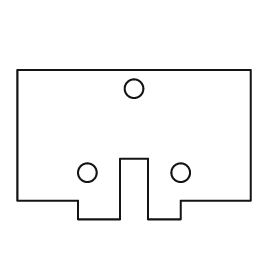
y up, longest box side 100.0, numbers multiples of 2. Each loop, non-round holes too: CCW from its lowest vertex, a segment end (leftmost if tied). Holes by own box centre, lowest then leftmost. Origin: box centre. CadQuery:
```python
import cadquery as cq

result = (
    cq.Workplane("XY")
    .moveTo(-24.0, -32.0)
    .lineTo(-6.0, -32.0)
    .lineTo(-6.0, -6.0)
    .lineTo(6.0, -6.0)
    .lineTo(6.0, -32.0)
    .lineTo(20.0, -32.0)
    .lineTo(20.0, -24.0)
    .lineTo(50.0, -24.0)
    .lineTo(50.0, 32.0)
    .lineTo(-50.0, 32.0)
    .lineTo(-50.0, -24.0)
    .lineTo(-24.0, -24.0)
    .close()
    .moveTo(-20.0, -12.0)
    .circle(4.0)
    .moveTo(20.0, -12.0)
    .circle(4.0)
    .moveTo(0.0, 24.0)
    .circle(4.0)
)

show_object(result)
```